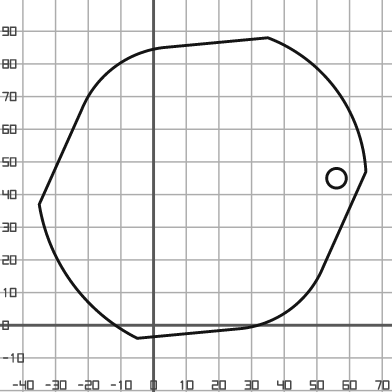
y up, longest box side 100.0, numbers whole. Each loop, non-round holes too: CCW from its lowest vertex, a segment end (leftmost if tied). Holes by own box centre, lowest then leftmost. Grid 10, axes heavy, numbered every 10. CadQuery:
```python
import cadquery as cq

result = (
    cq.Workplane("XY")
    .moveTo(-5.0, -4.0)
    .lineTo(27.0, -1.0)
    .threePointArc((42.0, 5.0), (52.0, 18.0))
    .lineTo(65.0, 47.0)
    .threePointArc((56.0, 72.0), (35.0, 88.0))
    .lineTo(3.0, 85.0)
    .threePointArc((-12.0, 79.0), (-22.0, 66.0))
    .lineTo(-35.0, 37.0)
    .threePointArc((-25.0, 13.0), (-5.0, -4.0))
    .close()
    .moveTo(56.0, 45.0)
    .circle(3.0)
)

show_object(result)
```